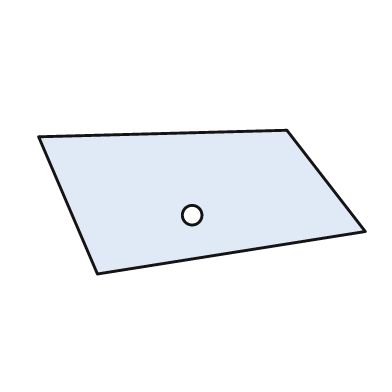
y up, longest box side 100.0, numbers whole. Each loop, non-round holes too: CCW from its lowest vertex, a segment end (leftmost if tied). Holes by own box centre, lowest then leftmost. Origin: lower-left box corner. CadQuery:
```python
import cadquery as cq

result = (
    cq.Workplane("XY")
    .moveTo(18.0, 0.0)
    .lineTo(100.0, 13.0)
    .lineTo(76.0, 44.0)
    .lineTo(0.0, 42.0)
    .close()
    .moveTo(47.0, 18.0)
    .circle(3.0)
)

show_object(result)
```